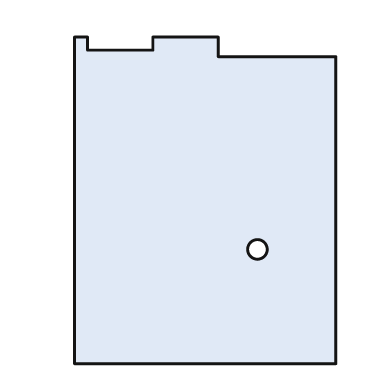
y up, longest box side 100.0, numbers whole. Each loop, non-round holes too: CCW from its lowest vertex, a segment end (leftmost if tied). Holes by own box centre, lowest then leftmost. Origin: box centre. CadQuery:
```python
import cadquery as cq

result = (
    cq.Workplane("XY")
    .moveTo(-40.0, -50.0)
    .lineTo(40.0, -50.0)
    .lineTo(40.0, 44.0)
    .lineTo(4.0, 44.0)
    .lineTo(4.0, 50.0)
    .lineTo(-16.0, 50.0)
    .lineTo(-16.0, 46.0)
    .lineTo(-36.0, 46.0)
    .lineTo(-36.0, 50.0)
    .lineTo(-40.0, 50.0)
    .close()
    .moveTo(16.0, -15.0)
    .circle(3.0)
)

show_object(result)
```